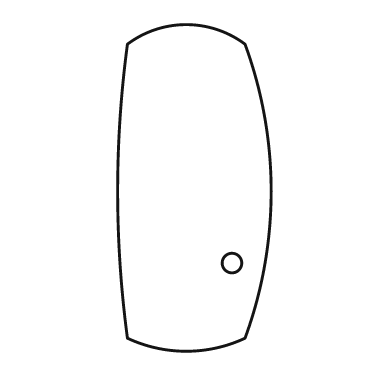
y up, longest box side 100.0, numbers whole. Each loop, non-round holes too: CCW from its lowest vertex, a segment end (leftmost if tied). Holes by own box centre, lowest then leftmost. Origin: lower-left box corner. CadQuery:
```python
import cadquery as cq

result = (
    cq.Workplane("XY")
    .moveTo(3.0, 4.0)
    .threePointArc((21.0, 0.0), (39.0, 4.0))
    .threePointArc((47.0, 49.0), (39.0, 94.0))
    .threePointArc((21.0, 100.0), (3.0, 94.0))
    .threePointArc((0.0, 49.0), (3.0, 4.0))
    .close()
    .moveTo(35.0, 27.0)
    .circle(3.0)
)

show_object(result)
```